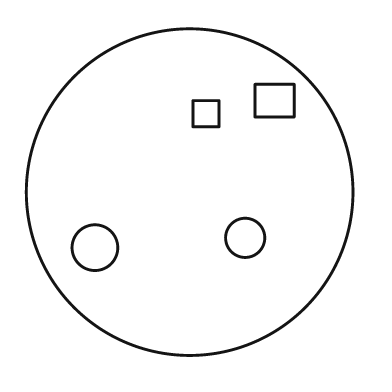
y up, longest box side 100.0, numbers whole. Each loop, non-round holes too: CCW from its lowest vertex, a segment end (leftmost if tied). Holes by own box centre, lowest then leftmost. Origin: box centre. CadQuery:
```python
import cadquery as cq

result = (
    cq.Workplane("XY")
    .moveTo(0.0, 0.0)
    .circle(50.0)
    .moveTo(-29.0, -17.0)
    .circle(7.0)
    .moveTo(17.0, -14.0)
    .circle(6.0)
    .moveTo(1.0, 20.0)
    .lineTo(9.0, 20.0)
    .lineTo(9.0, 28.0)
    .lineTo(1.0, 28.0)
    .close()
    .moveTo(20.0, 23.0)
    .lineTo(32.0, 23.0)
    .lineTo(32.0, 33.0)
    .lineTo(20.0, 33.0)
    .close()
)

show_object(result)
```